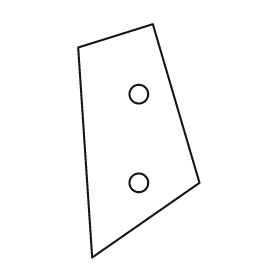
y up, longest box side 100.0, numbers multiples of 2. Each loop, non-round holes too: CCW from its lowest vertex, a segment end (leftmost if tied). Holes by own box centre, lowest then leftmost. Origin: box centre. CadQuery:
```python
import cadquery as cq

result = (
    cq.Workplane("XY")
    .moveTo(-20.0, -50.0)
    .lineTo(26.0, -18.0)
    .lineTo(6.0, 50.0)
    .lineTo(-26.0, 40.0)
    .close()
    .moveTo(0.0, -18.0)
    .circle(4.0)
    .moveTo(0.0, 20.0)
    .circle(4.0)
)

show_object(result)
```